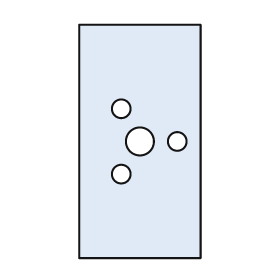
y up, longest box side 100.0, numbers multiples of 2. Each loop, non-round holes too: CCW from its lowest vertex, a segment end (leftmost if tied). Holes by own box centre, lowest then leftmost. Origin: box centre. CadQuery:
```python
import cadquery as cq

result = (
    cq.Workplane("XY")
    .moveTo(-26.0, -50.0)
    .lineTo(26.0, -50.0)
    .lineTo(26.0, 50.0)
    .lineTo(-26.0, 50.0)
    .close()
    .moveTo(-8.0, -14.0)
    .circle(4.0)
    .moveTo(0.0, 0.0)
    .circle(6.0)
    .moveTo(16.0, 0.0)
    .circle(4.0)
    .moveTo(-8.0, 14.0)
    .circle(4.0)
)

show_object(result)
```